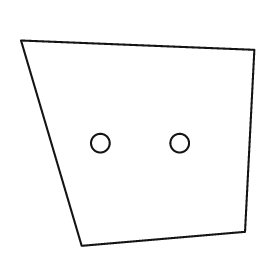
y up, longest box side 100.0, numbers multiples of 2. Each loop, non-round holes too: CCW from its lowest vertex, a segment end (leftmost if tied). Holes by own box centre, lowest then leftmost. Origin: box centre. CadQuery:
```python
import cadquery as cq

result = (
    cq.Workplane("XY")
    .moveTo(-24.0, -44.0)
    .lineTo(46.0, -38.0)
    .lineTo(50.0, 40.0)
    .lineTo(-50.0, 44.0)
    .close()
    .moveTo(-16.0, 0.0)
    .circle(4.0)
    .moveTo(18.0, 0.0)
    .circle(4.0)
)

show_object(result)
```